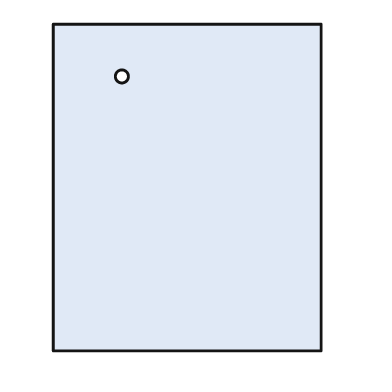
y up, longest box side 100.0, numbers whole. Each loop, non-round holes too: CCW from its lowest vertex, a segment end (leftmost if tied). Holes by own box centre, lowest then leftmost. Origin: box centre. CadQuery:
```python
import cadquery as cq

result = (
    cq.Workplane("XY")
    .moveTo(-41.0, -50.0)
    .lineTo(41.0, -50.0)
    .lineTo(41.0, 50.0)
    .lineTo(-41.0, 50.0)
    .close()
    .moveTo(-20.0, 34.0)
    .circle(2.0)
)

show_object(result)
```